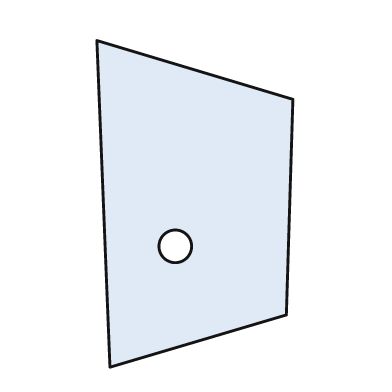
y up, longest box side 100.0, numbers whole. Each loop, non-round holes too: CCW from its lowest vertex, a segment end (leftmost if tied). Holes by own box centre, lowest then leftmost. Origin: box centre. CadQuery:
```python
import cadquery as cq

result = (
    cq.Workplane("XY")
    .moveTo(-26.0, -50.0)
    .lineTo(28.0, -34.0)
    .lineTo(30.0, 32.0)
    .lineTo(-30.0, 50.0)
    .close()
    .moveTo(-6.0, -13.0)
    .circle(5.0)
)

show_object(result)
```